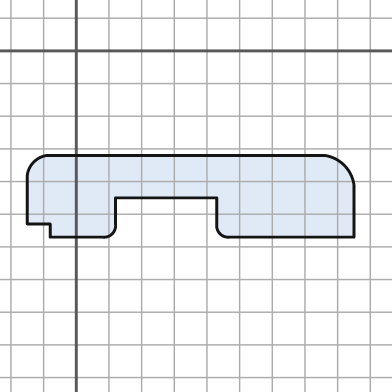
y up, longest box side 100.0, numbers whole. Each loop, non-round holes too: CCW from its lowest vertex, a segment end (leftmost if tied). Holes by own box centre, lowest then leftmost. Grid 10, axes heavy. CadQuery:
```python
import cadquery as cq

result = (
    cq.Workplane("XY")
    .moveTo(-8.0, -57.0)
    .lineTo(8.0, -57.0)
    .threePointArc((11.0, -56.0), (12.0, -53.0))
    .lineTo(12.0, -45.0)
    .lineTo(43.0, -45.0)
    .lineTo(43.0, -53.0)
    .threePointArc((44.0, -56.0), (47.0, -57.0))
    .lineTo(85.0, -57.0)
    .lineTo(85.0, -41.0)
    .threePointArc((82.0, -35.0), (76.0, -32.0))
    .lineTo(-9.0, -32.0)
    .threePointArc((-13.0, -34.0), (-15.0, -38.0))
    .lineTo(-15.0, -53.0)
    .lineTo(-8.0, -53.0)
    .close()
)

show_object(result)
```